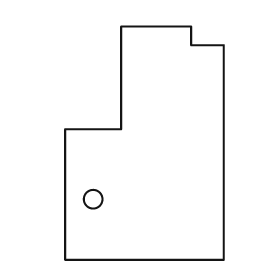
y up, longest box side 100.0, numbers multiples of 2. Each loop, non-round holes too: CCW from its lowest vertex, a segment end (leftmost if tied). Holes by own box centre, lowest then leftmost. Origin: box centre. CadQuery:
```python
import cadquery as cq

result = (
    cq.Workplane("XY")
    .moveTo(-34.0, -50.0)
    .lineTo(34.0, -50.0)
    .lineTo(34.0, 42.0)
    .lineTo(20.0, 42.0)
    .lineTo(20.0, 50.0)
    .lineTo(-10.0, 50.0)
    .lineTo(-10.0, 6.0)
    .lineTo(-34.0, 6.0)
    .close()
    .moveTo(-22.0, -24.0)
    .circle(4.0)
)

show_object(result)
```